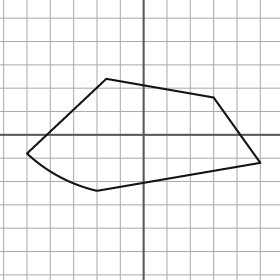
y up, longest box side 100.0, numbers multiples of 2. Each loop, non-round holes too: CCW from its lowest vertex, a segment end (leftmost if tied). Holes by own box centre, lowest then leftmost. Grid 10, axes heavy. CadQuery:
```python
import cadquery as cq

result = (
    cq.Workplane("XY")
    .moveTo(-20.0, -24.0)
    .lineTo(50.0, -12.0)
    .lineTo(30.0, 16.0)
    .lineTo(-16.0, 24.0)
    .lineTo(-50.0, -8.0)
    .threePointArc((-36.0, -18.0), (-20.0, -24.0))
    .close()
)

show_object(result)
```